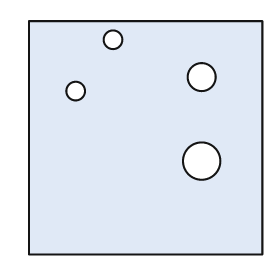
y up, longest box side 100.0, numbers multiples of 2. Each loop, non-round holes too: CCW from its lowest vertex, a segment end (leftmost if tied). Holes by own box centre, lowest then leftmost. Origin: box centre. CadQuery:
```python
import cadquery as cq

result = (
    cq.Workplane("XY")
    .moveTo(-50.0, -50.0)
    .lineTo(50.0, -50.0)
    .lineTo(50.0, 50.0)
    .lineTo(-50.0, 50.0)
    .close()
    .moveTo(24.0, -10.0)
    .circle(8.0)
    .moveTo(-30.0, 20.0)
    .circle(4.0)
    .moveTo(24.0, 26.0)
    .circle(6.0)
    .moveTo(-14.0, 42.0)
    .circle(4.0)
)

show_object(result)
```